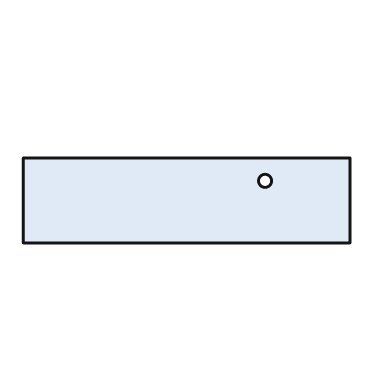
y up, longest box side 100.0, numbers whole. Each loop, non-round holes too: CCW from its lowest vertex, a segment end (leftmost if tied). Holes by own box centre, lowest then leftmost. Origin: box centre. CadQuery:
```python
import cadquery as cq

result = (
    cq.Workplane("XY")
    .moveTo(-50.0, -13.0)
    .lineTo(50.0, -13.0)
    .lineTo(50.0, 13.0)
    .lineTo(-50.0, 13.0)
    .close()
    .moveTo(24.0, 6.0)
    .circle(2.0)
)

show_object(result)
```